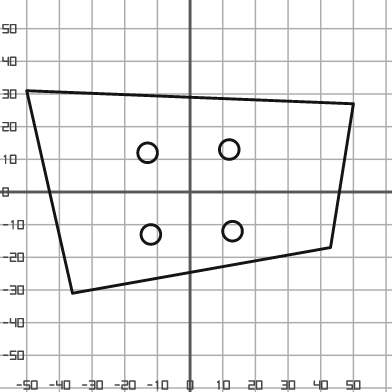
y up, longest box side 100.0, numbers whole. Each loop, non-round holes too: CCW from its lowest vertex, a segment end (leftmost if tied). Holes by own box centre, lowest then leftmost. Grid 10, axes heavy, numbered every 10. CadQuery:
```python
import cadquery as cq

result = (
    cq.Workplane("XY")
    .moveTo(-36.0, -31.0)
    .lineTo(43.0, -17.0)
    .lineTo(50.0, 27.0)
    .lineTo(-50.0, 31.0)
    .close()
    .moveTo(-12.0, -13.0)
    .circle(3.0)
    .moveTo(13.0, -12.0)
    .circle(3.0)
    .moveTo(-13.0, 12.0)
    .circle(3.0)
    .moveTo(12.0, 13.0)
    .circle(3.0)
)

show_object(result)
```